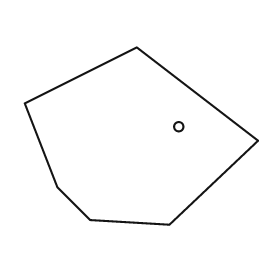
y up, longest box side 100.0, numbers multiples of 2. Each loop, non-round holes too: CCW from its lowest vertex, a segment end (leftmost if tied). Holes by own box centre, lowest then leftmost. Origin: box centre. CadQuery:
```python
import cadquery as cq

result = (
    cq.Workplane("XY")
    .moveTo(12.0, -38.0)
    .lineTo(50.0, -2.0)
    .lineTo(-2.0, 38.0)
    .lineTo(-50.0, 14.0)
    .lineTo(-36.0, -22.0)
    .lineTo(-22.0, -36.0)
    .close()
    .moveTo(16.0, 4.0)
    .circle(2.0)
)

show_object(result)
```